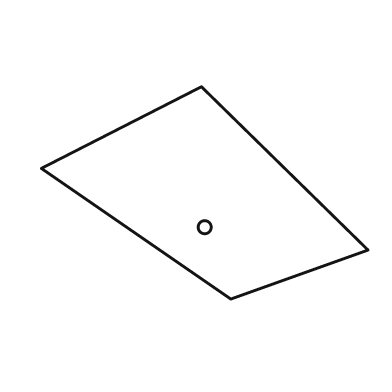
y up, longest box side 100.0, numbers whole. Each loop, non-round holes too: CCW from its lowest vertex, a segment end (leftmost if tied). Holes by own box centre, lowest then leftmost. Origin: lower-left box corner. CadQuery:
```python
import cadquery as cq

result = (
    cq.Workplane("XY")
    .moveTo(58.0, 0.0)
    .lineTo(100.0, 15.0)
    .lineTo(49.0, 65.0)
    .lineTo(0.0, 40.0)
    .close()
    .moveTo(50.0, 22.0)
    .circle(2.0)
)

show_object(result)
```